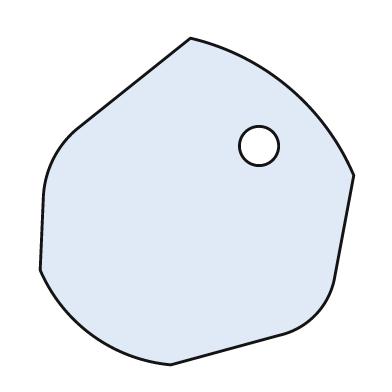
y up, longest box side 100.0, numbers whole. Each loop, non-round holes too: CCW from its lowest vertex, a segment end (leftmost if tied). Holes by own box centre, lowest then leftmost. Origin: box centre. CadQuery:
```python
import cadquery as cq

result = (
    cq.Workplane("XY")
    .moveTo(-8.0, -50.0)
    .lineTo(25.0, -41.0)
    .threePointArc((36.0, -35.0), (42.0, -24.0))
    .lineTo(48.0, 8.0)
    .threePointArc((28.0, 35.0), (-2.0, 50.0))
    .lineTo(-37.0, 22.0)
    .threePointArc((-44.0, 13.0), (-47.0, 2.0))
    .lineTo(-48.0, -21.0)
    .threePointArc((-32.0, -41.0), (-8.0, -50.0))
    .close()
    .moveTo(19.0, 17.0)
    .circle(6.0)
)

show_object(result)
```